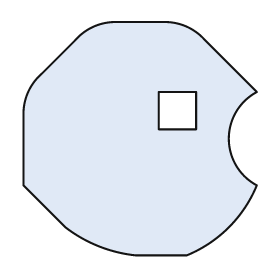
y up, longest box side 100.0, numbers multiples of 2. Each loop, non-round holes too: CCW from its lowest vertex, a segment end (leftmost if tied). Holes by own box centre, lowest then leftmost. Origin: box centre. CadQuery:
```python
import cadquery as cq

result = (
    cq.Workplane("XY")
    .moveTo(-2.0, -50.0)
    .lineTo(20.0, -50.0)
    .threePointArc((38.0, -38.0), (50.0, -20.0))
    .threePointArc((38.0, 0.0), (50.0, 20.0))
    .lineTo(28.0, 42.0)
    .threePointArc((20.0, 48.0), (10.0, 50.0))
    .lineTo(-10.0, 50.0)
    .threePointArc((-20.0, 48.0), (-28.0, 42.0))
    .lineTo(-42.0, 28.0)
    .threePointArc((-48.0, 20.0), (-50.0, 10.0))
    .lineTo(-50.0, -20.0)
    .lineTo(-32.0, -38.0)
    .threePointArc((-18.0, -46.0), (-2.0, -50.0))
    .close()
    .moveTo(8.0, 4.0)
    .lineTo(24.0, 4.0)
    .lineTo(24.0, 20.0)
    .lineTo(8.0, 20.0)
    .close()
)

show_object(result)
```